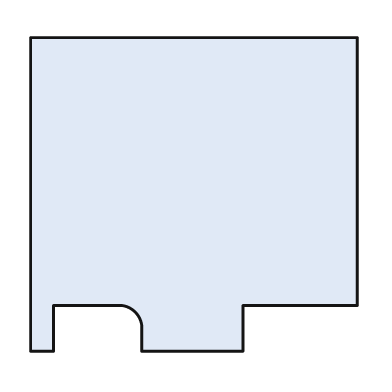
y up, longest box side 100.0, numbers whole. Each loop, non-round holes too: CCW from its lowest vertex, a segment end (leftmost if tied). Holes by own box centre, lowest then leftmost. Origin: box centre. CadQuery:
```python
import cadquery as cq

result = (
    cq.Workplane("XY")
    .moveTo(-50.0, -48.0)
    .lineTo(-43.0, -48.0)
    .lineTo(-43.0, -34.0)
    .lineTo(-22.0, -34.0)
    .threePointArc((-18.0, -36.0), (-16.0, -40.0))
    .lineTo(-16.0, -48.0)
    .lineTo(15.0, -48.0)
    .lineTo(15.0, -34.0)
    .lineTo(50.0, -34.0)
    .lineTo(50.0, 48.0)
    .lineTo(-50.0, 48.0)
    .close()
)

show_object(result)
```